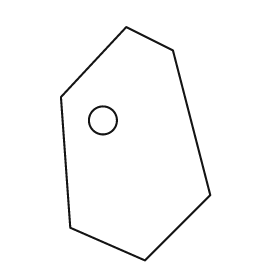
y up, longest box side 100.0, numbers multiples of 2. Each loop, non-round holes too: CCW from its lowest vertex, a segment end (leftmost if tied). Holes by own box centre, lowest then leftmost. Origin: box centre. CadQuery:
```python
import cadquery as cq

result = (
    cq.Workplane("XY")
    .moveTo(4.0, -50.0)
    .lineTo(32.0, -22.0)
    .lineTo(16.0, 40.0)
    .lineTo(-4.0, 50.0)
    .lineTo(-32.0, 20.0)
    .lineTo(-28.0, -36.0)
    .close()
    .moveTo(-14.0, 10.0)
    .circle(6.0)
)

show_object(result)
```